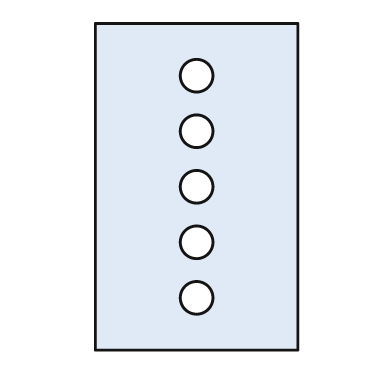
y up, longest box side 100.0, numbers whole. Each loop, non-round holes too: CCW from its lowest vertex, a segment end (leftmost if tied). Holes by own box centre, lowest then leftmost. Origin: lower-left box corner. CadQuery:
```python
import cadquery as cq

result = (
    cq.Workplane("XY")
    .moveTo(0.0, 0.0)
    .lineTo(62.0, 0.0)
    .lineTo(62.0, 100.0)
    .lineTo(0.0, 100.0)
    .close()
    .moveTo(31.0, 16.0)
    .circle(5.0)
    .moveTo(31.0, 33.0)
    .circle(5.0)
    .moveTo(31.0, 50.0)
    .circle(5.0)
    .moveTo(31.0, 67.0)
    .circle(5.0)
    .moveTo(31.0, 84.0)
    .circle(5.0)
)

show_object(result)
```